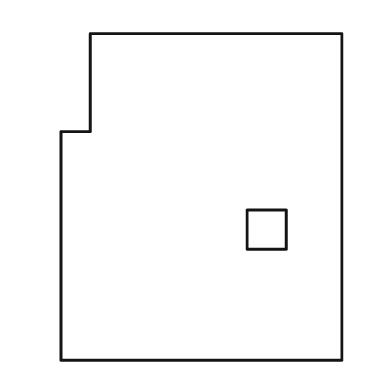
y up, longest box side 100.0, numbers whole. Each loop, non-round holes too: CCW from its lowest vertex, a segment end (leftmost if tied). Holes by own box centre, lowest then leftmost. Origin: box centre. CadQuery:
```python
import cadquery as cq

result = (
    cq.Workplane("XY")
    .moveTo(-43.0, -50.0)
    .lineTo(43.0, -50.0)
    .lineTo(43.0, 50.0)
    .lineTo(-34.0, 50.0)
    .lineTo(-34.0, 20.0)
    .lineTo(-43.0, 20.0)
    .close()
    .moveTo(14.0, -16.0)
    .lineTo(26.0, -16.0)
    .lineTo(26.0, -4.0)
    .lineTo(14.0, -4.0)
    .close()
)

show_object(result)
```